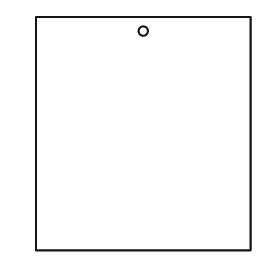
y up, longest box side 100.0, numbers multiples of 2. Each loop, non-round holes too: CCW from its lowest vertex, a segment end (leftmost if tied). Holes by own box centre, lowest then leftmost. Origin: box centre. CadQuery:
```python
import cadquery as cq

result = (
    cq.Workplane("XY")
    .moveTo(-46.0, -50.0)
    .lineTo(46.0, -50.0)
    .lineTo(46.0, 50.0)
    .lineTo(-46.0, 50.0)
    .close()
    .moveTo(0.0, 44.0)
    .circle(2.0)
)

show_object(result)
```